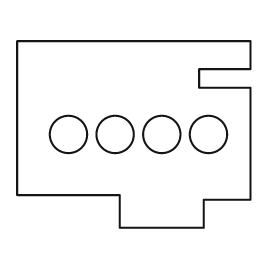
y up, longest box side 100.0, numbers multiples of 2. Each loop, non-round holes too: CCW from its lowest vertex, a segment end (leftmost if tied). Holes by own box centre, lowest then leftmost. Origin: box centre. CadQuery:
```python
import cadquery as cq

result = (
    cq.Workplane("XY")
    .moveTo(-6.0, -40.0)
    .lineTo(30.0, -40.0)
    .lineTo(30.0, -28.0)
    .lineTo(50.0, -28.0)
    .lineTo(50.0, 20.0)
    .lineTo(28.0, 20.0)
    .lineTo(28.0, 28.0)
    .lineTo(50.0, 28.0)
    .lineTo(50.0, 40.0)
    .lineTo(-50.0, 40.0)
    .lineTo(-50.0, -26.0)
    .lineTo(-6.0, -26.0)
    .close()
    .moveTo(-28.0, 0.0)
    .circle(8.0)
    .moveTo(-8.0, 0.0)
    .circle(8.0)
    .moveTo(12.0, 0.0)
    .circle(8.0)
    .moveTo(32.0, 0.0)
    .circle(8.0)
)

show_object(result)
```